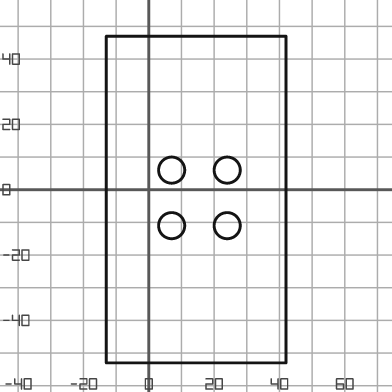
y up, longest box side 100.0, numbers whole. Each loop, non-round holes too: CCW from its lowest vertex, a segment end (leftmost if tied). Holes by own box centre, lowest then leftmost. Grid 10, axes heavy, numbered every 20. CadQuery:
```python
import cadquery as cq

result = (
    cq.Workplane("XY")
    .moveTo(-13.0, -53.0)
    .lineTo(42.0, -53.0)
    .lineTo(42.0, 47.0)
    .lineTo(-13.0, 47.0)
    .close()
    .moveTo(7.0, -11.0)
    .circle(4.0)
    .moveTo(24.0, -11.0)
    .circle(4.0)
    .moveTo(7.0, 6.0)
    .circle(4.0)
    .moveTo(24.0, 6.0)
    .circle(4.0)
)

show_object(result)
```